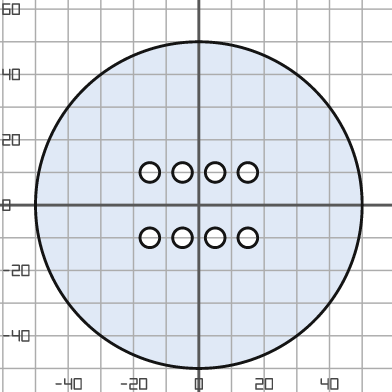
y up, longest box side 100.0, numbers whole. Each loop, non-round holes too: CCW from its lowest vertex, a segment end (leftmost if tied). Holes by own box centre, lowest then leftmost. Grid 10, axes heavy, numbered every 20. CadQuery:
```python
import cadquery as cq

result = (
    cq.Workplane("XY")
    .moveTo(0.0, 0.0)
    .circle(50.0)
    .moveTo(-15.0, -10.0)
    .circle(3.0)
    .moveTo(-5.0, -10.0)
    .circle(3.0)
    .moveTo(5.0, -10.0)
    .circle(3.0)
    .moveTo(15.0, -10.0)
    .circle(3.0)
    .moveTo(-15.0, 10.0)
    .circle(3.0)
    .moveTo(-5.0, 10.0)
    .circle(3.0)
    .moveTo(5.0, 10.0)
    .circle(3.0)
    .moveTo(15.0, 10.0)
    .circle(3.0)
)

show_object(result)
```